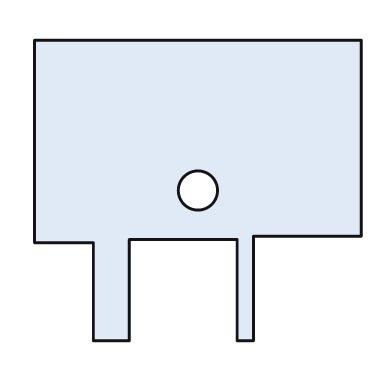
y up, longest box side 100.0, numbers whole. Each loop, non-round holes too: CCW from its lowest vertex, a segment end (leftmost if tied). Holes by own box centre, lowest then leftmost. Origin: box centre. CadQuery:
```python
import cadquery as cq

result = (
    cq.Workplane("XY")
    .moveTo(-32.0, -46.0)
    .lineTo(-21.0, -46.0)
    .lineTo(-21.0, -15.0)
    .lineTo(12.0, -15.0)
    .lineTo(12.0, -46.0)
    .lineTo(17.0, -46.0)
    .lineTo(17.0, -14.0)
    .lineTo(50.0, -14.0)
    .lineTo(50.0, 46.0)
    .lineTo(-50.0, 46.0)
    .lineTo(-50.0, -16.0)
    .lineTo(-32.0, -16.0)
    .close()
    .moveTo(0.0, 0.0)
    .circle(6.0)
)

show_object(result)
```